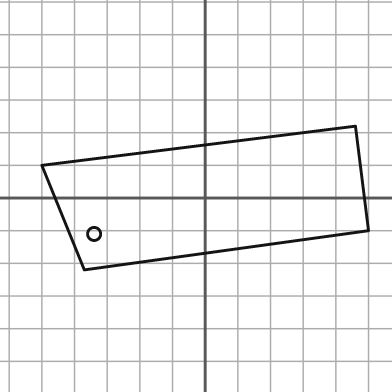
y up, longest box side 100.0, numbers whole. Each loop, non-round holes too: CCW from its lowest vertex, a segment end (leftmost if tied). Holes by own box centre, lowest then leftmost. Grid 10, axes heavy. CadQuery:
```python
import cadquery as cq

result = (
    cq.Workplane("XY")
    .moveTo(-37.0, -22.0)
    .lineTo(50.0, -10.0)
    .lineTo(46.0, 22.0)
    .lineTo(-50.0, 10.0)
    .close()
    .moveTo(-34.0, -11.0)
    .circle(2.0)
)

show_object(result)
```